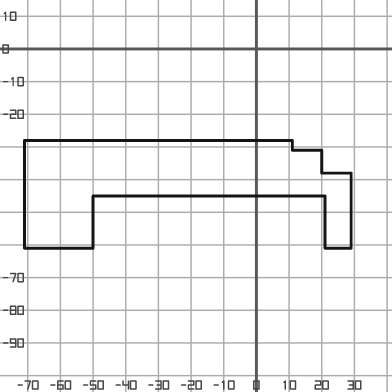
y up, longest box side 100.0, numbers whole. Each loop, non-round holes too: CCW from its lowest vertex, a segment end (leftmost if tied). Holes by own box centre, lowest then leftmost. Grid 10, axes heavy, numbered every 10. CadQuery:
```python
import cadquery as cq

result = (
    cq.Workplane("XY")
    .moveTo(-71.0, -61.0)
    .lineTo(-50.0, -61.0)
    .lineTo(-50.0, -45.0)
    .lineTo(21.0, -45.0)
    .lineTo(21.0, -61.0)
    .lineTo(29.0, -61.0)
    .lineTo(29.0, -38.0)
    .lineTo(20.0, -38.0)
    .lineTo(20.0, -31.0)
    .lineTo(11.0, -31.0)
    .lineTo(11.0, -28.0)
    .lineTo(-71.0, -28.0)
    .close()
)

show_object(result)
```